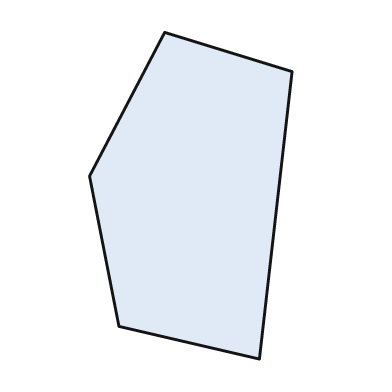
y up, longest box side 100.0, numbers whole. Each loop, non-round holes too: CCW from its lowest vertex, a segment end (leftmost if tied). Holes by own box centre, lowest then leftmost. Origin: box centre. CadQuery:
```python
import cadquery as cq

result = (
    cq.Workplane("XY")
    .moveTo(21.0, -50.0)
    .lineTo(31.0, 38.0)
    .lineTo(-8.0, 50.0)
    .lineTo(-31.0, 6.0)
    .lineTo(-22.0, -40.0)
    .close()
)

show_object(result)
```